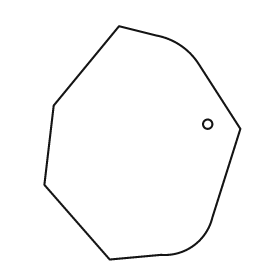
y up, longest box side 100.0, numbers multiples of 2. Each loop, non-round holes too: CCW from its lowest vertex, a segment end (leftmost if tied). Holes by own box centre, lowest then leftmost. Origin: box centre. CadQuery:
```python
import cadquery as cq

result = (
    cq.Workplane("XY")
    .moveTo(-14.0, -50.0)
    .lineTo(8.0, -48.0)
    .threePointArc((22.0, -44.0), (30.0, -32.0))
    .lineTo(42.0, 6.0)
    .lineTo(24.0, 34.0)
    .threePointArc((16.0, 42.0), (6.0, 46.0))
    .lineTo(-10.0, 50.0)
    .lineTo(-38.0, 16.0)
    .lineTo(-42.0, -18.0)
    .close()
    .moveTo(28.0, 8.0)
    .circle(2.0)
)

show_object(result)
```